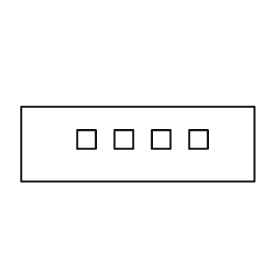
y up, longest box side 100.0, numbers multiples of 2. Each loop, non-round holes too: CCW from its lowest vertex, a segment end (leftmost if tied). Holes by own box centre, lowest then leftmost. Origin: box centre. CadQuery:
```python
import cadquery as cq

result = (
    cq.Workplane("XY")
    .moveTo(-50.0, -16.0)
    .lineTo(50.0, -16.0)
    .lineTo(50.0, 16.0)
    .lineTo(-50.0, 16.0)
    .close()
    .moveTo(-26.0, -2.0)
    .lineTo(-18.0, -2.0)
    .lineTo(-18.0, 6.0)
    .lineTo(-26.0, 6.0)
    .close()
    .moveTo(-10.0, -2.0)
    .lineTo(-2.0, -2.0)
    .lineTo(-2.0, 6.0)
    .lineTo(-10.0, 6.0)
    .close()
    .moveTo(6.0, -2.0)
    .lineTo(14.0, -2.0)
    .lineTo(14.0, 6.0)
    .lineTo(6.0, 6.0)
    .close()
    .moveTo(22.0, -2.0)
    .lineTo(30.0, -2.0)
    .lineTo(30.0, 6.0)
    .lineTo(22.0, 6.0)
    .close()
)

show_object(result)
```